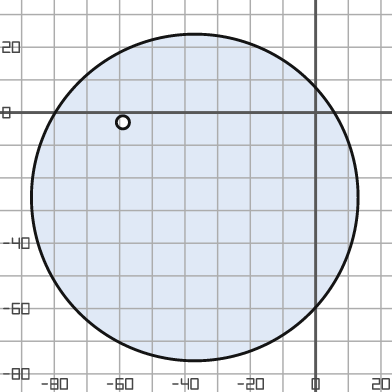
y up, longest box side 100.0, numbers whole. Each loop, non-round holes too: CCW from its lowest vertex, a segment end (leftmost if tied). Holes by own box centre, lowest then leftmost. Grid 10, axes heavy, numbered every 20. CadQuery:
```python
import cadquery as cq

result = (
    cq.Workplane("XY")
    .moveTo(-37.0, -26.0)
    .circle(50.0)
    .moveTo(-59.0, -3.0)
    .circle(2.0)
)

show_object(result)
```